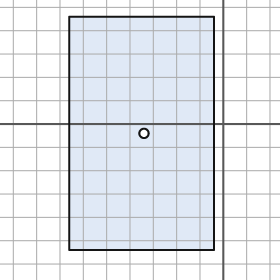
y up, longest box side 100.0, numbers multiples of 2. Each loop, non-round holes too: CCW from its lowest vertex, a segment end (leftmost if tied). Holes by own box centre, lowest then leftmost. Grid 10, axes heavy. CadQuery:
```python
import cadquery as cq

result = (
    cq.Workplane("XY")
    .moveTo(-66.0, -54.0)
    .lineTo(-4.0, -54.0)
    .lineTo(-4.0, 46.0)
    .lineTo(-66.0, 46.0)
    .close()
    .moveTo(-34.0, -4.0)
    .circle(2.0)
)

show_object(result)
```